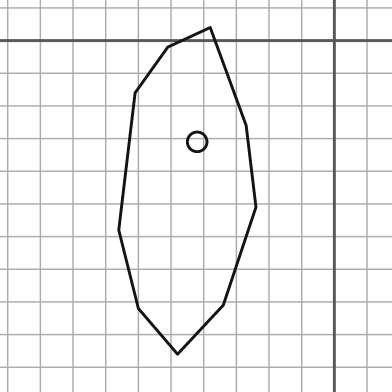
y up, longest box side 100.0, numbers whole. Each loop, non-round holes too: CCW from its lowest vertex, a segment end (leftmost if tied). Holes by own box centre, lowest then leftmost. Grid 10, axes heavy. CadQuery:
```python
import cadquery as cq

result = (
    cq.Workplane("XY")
    .moveTo(-48.0, -96.0)
    .lineTo(-34.0, -81.0)
    .lineTo(-24.0, -51.0)
    .lineTo(-27.0, -26.0)
    .lineTo(-38.0, 4.0)
    .lineTo(-51.0, -2.0)
    .lineTo(-61.0, -16.0)
    .lineTo(-66.0, -58.0)
    .lineTo(-60.0, -82.0)
    .close()
    .moveTo(-42.0, -31.0)
    .circle(3.0)
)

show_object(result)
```